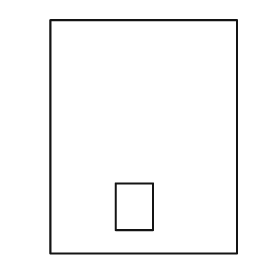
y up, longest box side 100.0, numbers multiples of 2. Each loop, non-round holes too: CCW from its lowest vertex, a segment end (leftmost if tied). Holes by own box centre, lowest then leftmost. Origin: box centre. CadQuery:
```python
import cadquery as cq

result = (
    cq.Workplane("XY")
    .moveTo(-40.0, -50.0)
    .lineTo(40.0, -50.0)
    .lineTo(40.0, 50.0)
    .lineTo(-40.0, 50.0)
    .close()
    .moveTo(-12.0, -40.0)
    .lineTo(4.0, -40.0)
    .lineTo(4.0, -20.0)
    .lineTo(-12.0, -20.0)
    .close()
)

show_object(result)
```